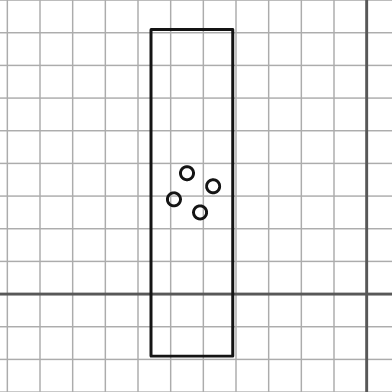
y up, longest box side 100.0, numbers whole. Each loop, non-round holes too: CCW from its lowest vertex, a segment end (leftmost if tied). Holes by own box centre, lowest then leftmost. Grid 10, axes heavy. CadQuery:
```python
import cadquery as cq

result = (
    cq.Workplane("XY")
    .moveTo(-66.0, -19.0)
    .lineTo(-41.0, -19.0)
    .lineTo(-41.0, 81.0)
    .lineTo(-66.0, 81.0)
    .close()
    .moveTo(-51.0, 25.0)
    .circle(2.0)
    .moveTo(-59.0, 29.0)
    .circle(2.0)
    .moveTo(-47.0, 33.0)
    .circle(2.0)
    .moveTo(-55.0, 37.0)
    .circle(2.0)
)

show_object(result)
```